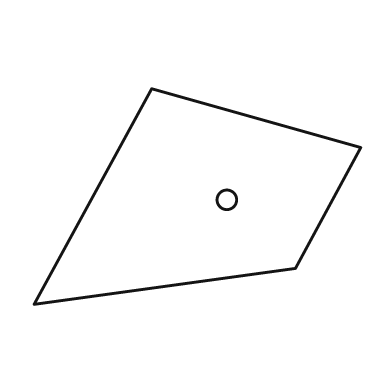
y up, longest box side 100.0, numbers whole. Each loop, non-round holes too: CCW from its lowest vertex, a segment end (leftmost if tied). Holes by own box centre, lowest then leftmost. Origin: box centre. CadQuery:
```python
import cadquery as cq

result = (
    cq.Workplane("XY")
    .moveTo(-50.0, -33.0)
    .lineTo(30.0, -22.0)
    .lineTo(50.0, 15.0)
    .lineTo(-14.0, 33.0)
    .close()
    .moveTo(9.0, -1.0)
    .circle(3.0)
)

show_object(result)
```